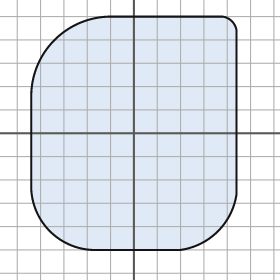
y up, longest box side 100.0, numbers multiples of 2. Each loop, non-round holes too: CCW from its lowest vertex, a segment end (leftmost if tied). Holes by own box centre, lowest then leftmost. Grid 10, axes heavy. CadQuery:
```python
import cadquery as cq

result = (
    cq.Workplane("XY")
    .moveTo(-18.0, -50.0)
    .lineTo(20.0, -50.0)
    .threePointArc((36.0, -42.0), (44.0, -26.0))
    .lineTo(44.0, 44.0)
    .threePointArc((42.0, 48.0), (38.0, 50.0))
    .lineTo(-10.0, 50.0)
    .threePointArc((-34.0, 40.0), (-44.0, 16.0))
    .lineTo(-44.0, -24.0)
    .threePointArc((-36.0, -42.0), (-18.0, -50.0))
    .close()
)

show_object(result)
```